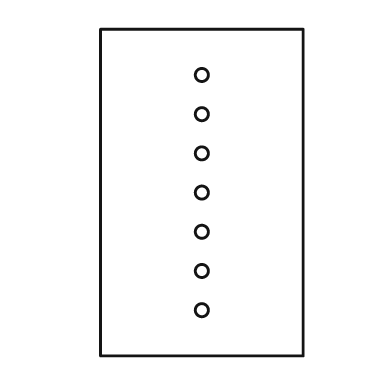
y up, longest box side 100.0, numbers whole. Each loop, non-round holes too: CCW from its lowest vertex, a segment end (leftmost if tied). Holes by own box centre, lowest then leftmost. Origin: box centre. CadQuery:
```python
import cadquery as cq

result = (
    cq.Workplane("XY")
    .moveTo(-31.0, -50.0)
    .lineTo(31.0, -50.0)
    .lineTo(31.0, 50.0)
    .lineTo(-31.0, 50.0)
    .close()
    .moveTo(0.0, -36.0)
    .circle(2.0)
    .moveTo(0.0, -24.0)
    .circle(2.0)
    .moveTo(0.0, -12.0)
    .circle(2.0)
    .moveTo(0.0, 0.0)
    .circle(2.0)
    .moveTo(0.0, 12.0)
    .circle(2.0)
    .moveTo(0.0, 24.0)
    .circle(2.0)
    .moveTo(0.0, 36.0)
    .circle(2.0)
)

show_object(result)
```